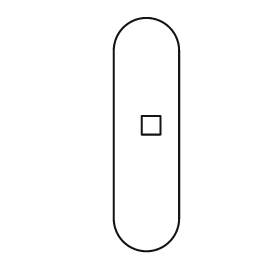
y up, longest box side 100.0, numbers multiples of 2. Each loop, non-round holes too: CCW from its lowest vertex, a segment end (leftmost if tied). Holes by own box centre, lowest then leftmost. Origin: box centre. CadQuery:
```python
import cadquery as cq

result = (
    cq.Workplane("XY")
    .moveTo(-14.0, -36.0)
    .threePointArc((0.0, -50.0), (14.0, -36.0))
    .lineTo(14.0, 36.0)
    .threePointArc((0.0, 50.0), (-14.0, 36.0))
    .close()
    .moveTo(-2.0, 0.0)
    .lineTo(6.0, 0.0)
    .lineTo(6.0, 8.0)
    .lineTo(-2.0, 8.0)
    .close()
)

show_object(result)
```